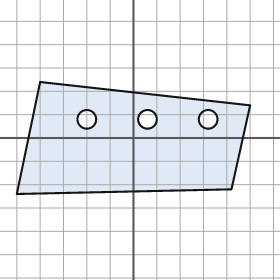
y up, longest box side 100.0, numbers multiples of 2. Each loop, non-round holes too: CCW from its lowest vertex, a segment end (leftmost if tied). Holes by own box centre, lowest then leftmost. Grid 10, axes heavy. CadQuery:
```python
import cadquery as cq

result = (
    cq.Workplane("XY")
    .moveTo(-50.0, -24.0)
    .lineTo(42.0, -22.0)
    .lineTo(50.0, 14.0)
    .lineTo(-40.0, 24.0)
    .close()
    .moveTo(-20.0, 8.0)
    .circle(4.0)
    .moveTo(6.0, 8.0)
    .circle(4.0)
    .moveTo(32.0, 8.0)
    .circle(4.0)
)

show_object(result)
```